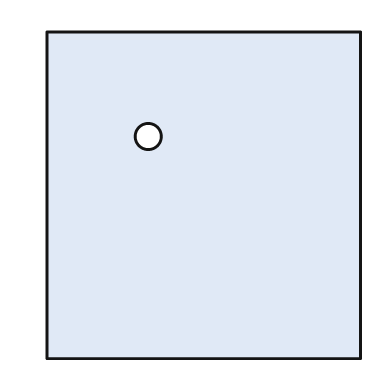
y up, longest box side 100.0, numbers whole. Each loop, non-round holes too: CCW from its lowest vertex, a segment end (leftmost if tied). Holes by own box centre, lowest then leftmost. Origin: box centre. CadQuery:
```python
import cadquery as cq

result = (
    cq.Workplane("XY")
    .moveTo(-48.0, -50.0)
    .lineTo(48.0, -50.0)
    .lineTo(48.0, 50.0)
    .lineTo(-48.0, 50.0)
    .close()
    .moveTo(-17.0, 18.0)
    .circle(4.0)
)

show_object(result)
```